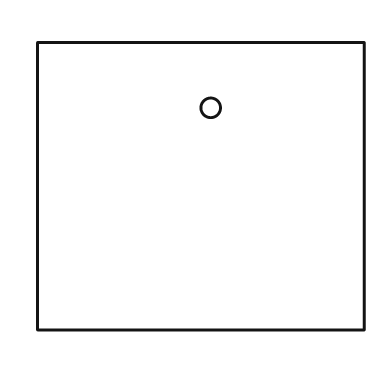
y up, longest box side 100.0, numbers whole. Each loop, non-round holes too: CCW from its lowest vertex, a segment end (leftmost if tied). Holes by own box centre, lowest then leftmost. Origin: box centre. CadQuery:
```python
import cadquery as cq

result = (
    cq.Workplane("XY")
    .moveTo(-50.0, -44.0)
    .lineTo(50.0, -44.0)
    .lineTo(50.0, 44.0)
    .lineTo(-50.0, 44.0)
    .close()
    .moveTo(3.0, 24.0)
    .circle(3.0)
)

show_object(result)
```